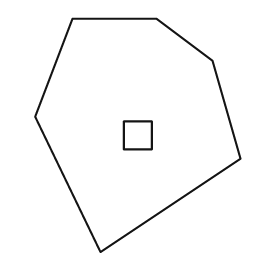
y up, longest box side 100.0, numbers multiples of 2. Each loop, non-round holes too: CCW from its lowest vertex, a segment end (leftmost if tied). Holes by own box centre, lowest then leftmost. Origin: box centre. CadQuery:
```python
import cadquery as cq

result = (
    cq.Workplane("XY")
    .moveTo(-16.0, -50.0)
    .lineTo(44.0, -10.0)
    .lineTo(32.0, 32.0)
    .lineTo(8.0, 50.0)
    .lineTo(-28.0, 50.0)
    .lineTo(-44.0, 8.0)
    .close()
    .moveTo(-6.0, -6.0)
    .lineTo(6.0, -6.0)
    .lineTo(6.0, 6.0)
    .lineTo(-6.0, 6.0)
    .close()
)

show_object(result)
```